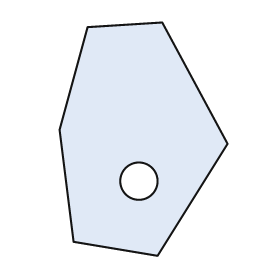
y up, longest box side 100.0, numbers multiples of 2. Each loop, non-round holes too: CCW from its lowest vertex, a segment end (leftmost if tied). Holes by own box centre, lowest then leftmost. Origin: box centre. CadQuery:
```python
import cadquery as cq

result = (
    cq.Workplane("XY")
    .moveTo(6.0, -50.0)
    .lineTo(36.0, -2.0)
    .lineTo(8.0, 50.0)
    .lineTo(-24.0, 48.0)
    .lineTo(-36.0, 4.0)
    .lineTo(-30.0, -44.0)
    .close()
    .moveTo(-2.0, -18.0)
    .circle(8.0)
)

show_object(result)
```